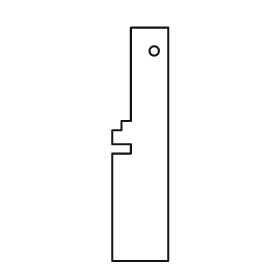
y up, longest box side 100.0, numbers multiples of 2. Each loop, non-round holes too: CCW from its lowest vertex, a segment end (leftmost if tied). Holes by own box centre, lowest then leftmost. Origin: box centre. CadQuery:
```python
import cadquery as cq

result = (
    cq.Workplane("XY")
    .moveTo(-12.0, -50.0)
    .lineTo(12.0, -50.0)
    .lineTo(12.0, 50.0)
    .lineTo(-4.0, 50.0)
    .lineTo(-4.0, 10.0)
    .lineTo(-8.0, 10.0)
    .lineTo(-8.0, 6.0)
    .lineTo(-12.0, 6.0)
    .lineTo(-12.0, 0.0)
    .lineTo(-4.0, 0.0)
    .lineTo(-4.0, -4.0)
    .lineTo(-12.0, -4.0)
    .close()
    .moveTo(6.0, 40.0)
    .circle(2.0)
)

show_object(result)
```